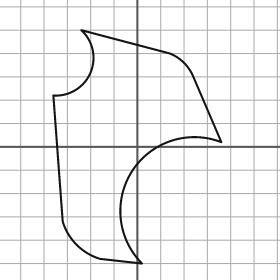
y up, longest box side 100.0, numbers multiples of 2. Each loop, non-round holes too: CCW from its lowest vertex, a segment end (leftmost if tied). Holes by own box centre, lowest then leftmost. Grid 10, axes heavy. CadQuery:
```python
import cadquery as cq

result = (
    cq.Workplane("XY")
    .moveTo(2.0, -50.0)
    .threePointArc((-2.0, -10.0), (36.0, 2.0))
    .lineTo(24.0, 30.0)
    .threePointArc((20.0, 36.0), (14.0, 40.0))
    .lineTo(-24.0, 50.0)
    .threePointArc((-20.0, 32.0), (-36.0, 22.0))
    .lineTo(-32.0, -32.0)
    .threePointArc((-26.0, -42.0), (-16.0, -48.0))
    .close()
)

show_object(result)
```